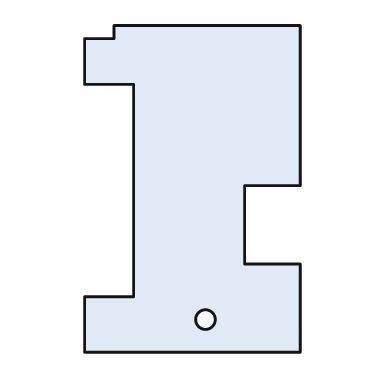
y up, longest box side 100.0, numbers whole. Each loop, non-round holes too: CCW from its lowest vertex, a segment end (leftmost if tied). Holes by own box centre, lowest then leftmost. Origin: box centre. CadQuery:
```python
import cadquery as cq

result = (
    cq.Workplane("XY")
    .moveTo(-33.0, -50.0)
    .lineTo(33.0, -50.0)
    .lineTo(33.0, -23.0)
    .lineTo(16.0, -23.0)
    .lineTo(16.0, 1.0)
    .lineTo(33.0, 1.0)
    .lineTo(33.0, 50.0)
    .lineTo(-24.0, 50.0)
    .lineTo(-24.0, 46.0)
    .lineTo(-33.0, 46.0)
    .lineTo(-33.0, 32.0)
    .lineTo(-18.0, 32.0)
    .lineTo(-18.0, -33.0)
    .lineTo(-33.0, -33.0)
    .close()
    .moveTo(4.0, -40.0)
    .circle(3.0)
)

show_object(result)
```